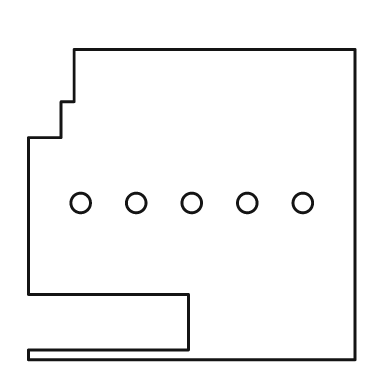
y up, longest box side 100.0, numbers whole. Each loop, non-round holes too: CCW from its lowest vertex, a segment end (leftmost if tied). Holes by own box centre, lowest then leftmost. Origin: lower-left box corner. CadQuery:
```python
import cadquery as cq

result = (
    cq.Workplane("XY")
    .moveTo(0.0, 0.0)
    .lineTo(100.0, 0.0)
    .lineTo(100.0, 95.0)
    .lineTo(14.0, 95.0)
    .lineTo(14.0, 79.0)
    .lineTo(10.0, 79.0)
    .lineTo(10.0, 68.0)
    .lineTo(0.0, 68.0)
    .lineTo(0.0, 20.0)
    .lineTo(49.0, 20.0)
    .lineTo(49.0, 3.0)
    .lineTo(0.0, 3.0)
    .close()
    .moveTo(16.0, 48.0)
    .circle(3.0)
    .moveTo(33.0, 48.0)
    .circle(3.0)
    .moveTo(50.0, 48.0)
    .circle(3.0)
    .moveTo(67.0, 48.0)
    .circle(3.0)
    .moveTo(84.0, 48.0)
    .circle(3.0)
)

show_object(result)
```